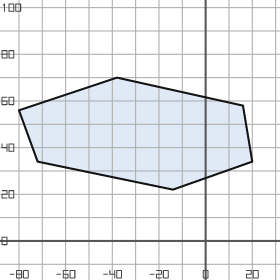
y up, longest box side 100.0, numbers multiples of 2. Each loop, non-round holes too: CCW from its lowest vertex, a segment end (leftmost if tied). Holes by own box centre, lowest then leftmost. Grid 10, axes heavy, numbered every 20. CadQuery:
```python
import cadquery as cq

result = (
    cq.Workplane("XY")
    .moveTo(-14.0, 22.0)
    .lineTo(20.0, 34.0)
    .lineTo(16.0, 58.0)
    .lineTo(-38.0, 70.0)
    .lineTo(-80.0, 56.0)
    .lineTo(-72.0, 34.0)
    .close()
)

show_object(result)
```